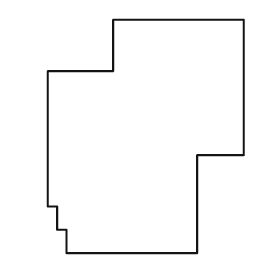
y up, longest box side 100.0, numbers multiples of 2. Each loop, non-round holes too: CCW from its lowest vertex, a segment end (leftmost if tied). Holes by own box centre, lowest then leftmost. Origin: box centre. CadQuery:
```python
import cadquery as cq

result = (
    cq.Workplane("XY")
    .moveTo(-34.0, -50.0)
    .lineTo(22.0, -50.0)
    .lineTo(22.0, -8.0)
    .lineTo(42.0, -8.0)
    .lineTo(42.0, 50.0)
    .lineTo(-14.0, 50.0)
    .lineTo(-14.0, 28.0)
    .lineTo(-42.0, 28.0)
    .lineTo(-42.0, -30.0)
    .lineTo(-38.0, -30.0)
    .lineTo(-38.0, -40.0)
    .lineTo(-34.0, -40.0)
    .close()
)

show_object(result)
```